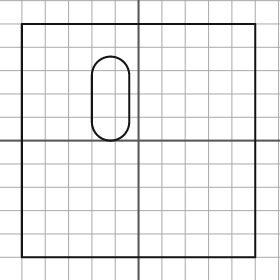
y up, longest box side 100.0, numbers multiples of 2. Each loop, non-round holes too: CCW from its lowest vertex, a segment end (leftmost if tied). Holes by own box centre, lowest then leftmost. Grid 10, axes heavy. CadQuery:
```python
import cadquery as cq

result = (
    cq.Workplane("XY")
    .moveTo(-50.0, -50.0)
    .lineTo(50.0, -50.0)
    .lineTo(50.0, 50.0)
    .lineTo(-50.0, 50.0)
    .close()
    .moveTo(-20.0, 8.0)
    .threePointArc((-12.0, 0.0), (-4.0, 8.0))
    .lineTo(-4.0, 28.0)
    .threePointArc((-12.0, 36.0), (-20.0, 28.0))
    .close()
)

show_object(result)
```